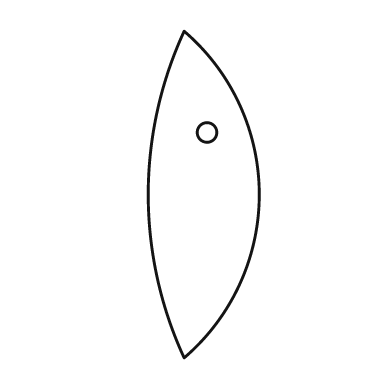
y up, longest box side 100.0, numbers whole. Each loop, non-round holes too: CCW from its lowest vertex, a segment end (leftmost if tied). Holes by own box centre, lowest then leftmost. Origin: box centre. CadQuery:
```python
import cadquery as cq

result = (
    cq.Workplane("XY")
    .moveTo(-6.0, -50.0)
    .threePointArc((17.0, 0.0), (-6.0, 50.0))
    .threePointArc((-17.0, 0.0), (-6.0, -50.0))
    .close()
    .moveTo(1.0, 19.0)
    .circle(3.0)
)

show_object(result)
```